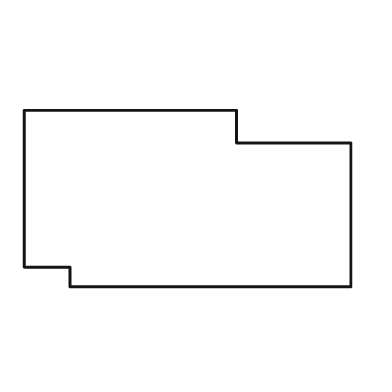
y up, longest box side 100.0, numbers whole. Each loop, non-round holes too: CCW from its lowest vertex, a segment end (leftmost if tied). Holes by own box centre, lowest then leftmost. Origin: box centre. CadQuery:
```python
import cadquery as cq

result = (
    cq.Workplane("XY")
    .moveTo(-36.0, -27.0)
    .lineTo(50.0, -27.0)
    .lineTo(50.0, 17.0)
    .lineTo(15.0, 17.0)
    .lineTo(15.0, 27.0)
    .lineTo(-50.0, 27.0)
    .lineTo(-50.0, -21.0)
    .lineTo(-36.0, -21.0)
    .close()
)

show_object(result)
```